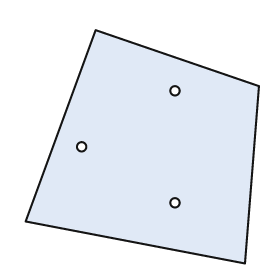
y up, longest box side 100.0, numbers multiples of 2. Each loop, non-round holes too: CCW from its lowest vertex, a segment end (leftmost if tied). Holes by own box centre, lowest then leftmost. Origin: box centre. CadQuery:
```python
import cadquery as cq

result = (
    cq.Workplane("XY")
    .moveTo(44.0, -50.0)
    .lineTo(50.0, 26.0)
    .lineTo(-20.0, 50.0)
    .lineTo(-50.0, -32.0)
    .close()
    .moveTo(14.0, -24.0)
    .circle(2.0)
    .moveTo(-26.0, 0.0)
    .circle(2.0)
    .moveTo(14.0, 24.0)
    .circle(2.0)
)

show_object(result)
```